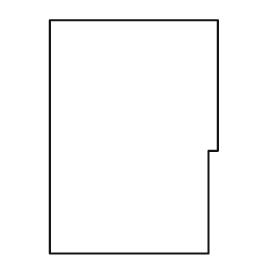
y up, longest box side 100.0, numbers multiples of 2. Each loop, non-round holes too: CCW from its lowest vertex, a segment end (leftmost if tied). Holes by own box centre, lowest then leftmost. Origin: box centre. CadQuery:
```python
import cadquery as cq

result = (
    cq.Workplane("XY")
    .moveTo(-36.0, -50.0)
    .lineTo(32.0, -50.0)
    .lineTo(32.0, -6.0)
    .lineTo(36.0, -6.0)
    .lineTo(36.0, 50.0)
    .lineTo(-36.0, 50.0)
    .close()
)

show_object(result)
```